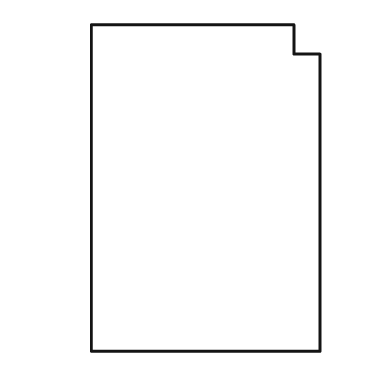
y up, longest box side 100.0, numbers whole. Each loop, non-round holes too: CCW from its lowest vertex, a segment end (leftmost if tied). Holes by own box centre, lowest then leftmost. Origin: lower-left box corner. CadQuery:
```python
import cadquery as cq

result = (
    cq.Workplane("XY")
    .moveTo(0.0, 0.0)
    .lineTo(70.0, 0.0)
    .lineTo(70.0, 91.0)
    .lineTo(62.0, 91.0)
    .lineTo(62.0, 100.0)
    .lineTo(0.0, 100.0)
    .close()
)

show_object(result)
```